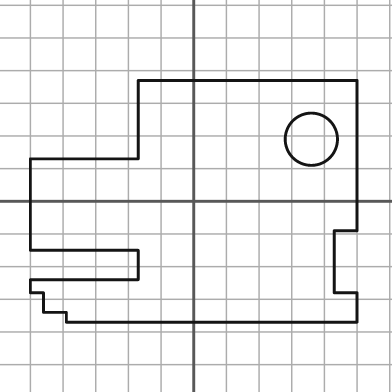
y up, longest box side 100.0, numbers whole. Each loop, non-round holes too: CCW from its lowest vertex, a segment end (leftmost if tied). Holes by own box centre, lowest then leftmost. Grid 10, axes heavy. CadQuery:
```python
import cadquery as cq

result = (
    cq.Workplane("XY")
    .moveTo(-39.0, -37.0)
    .lineTo(50.0, -37.0)
    .lineTo(50.0, -28.0)
    .lineTo(43.0, -28.0)
    .lineTo(43.0, -9.0)
    .lineTo(50.0, -9.0)
    .lineTo(50.0, 37.0)
    .lineTo(-17.0, 37.0)
    .lineTo(-17.0, 13.0)
    .lineTo(-50.0, 13.0)
    .lineTo(-50.0, -15.0)
    .lineTo(-17.0, -15.0)
    .lineTo(-17.0, -24.0)
    .lineTo(-50.0, -24.0)
    .lineTo(-50.0, -28.0)
    .lineTo(-46.0, -28.0)
    .lineTo(-46.0, -34.0)
    .lineTo(-39.0, -34.0)
    .close()
    .moveTo(36.0, 19.0)
    .circle(8.0)
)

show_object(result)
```